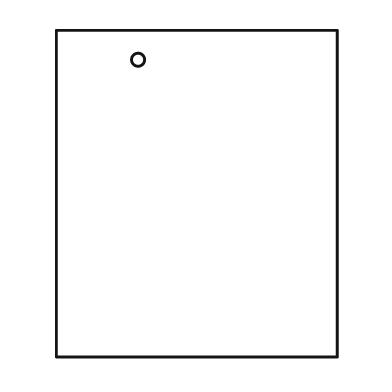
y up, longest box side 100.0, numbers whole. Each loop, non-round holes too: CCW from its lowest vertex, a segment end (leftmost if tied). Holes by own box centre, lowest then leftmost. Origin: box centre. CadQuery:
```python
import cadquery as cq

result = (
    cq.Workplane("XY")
    .moveTo(-43.0, -50.0)
    .lineTo(43.0, -50.0)
    .lineTo(43.0, 50.0)
    .lineTo(-43.0, 50.0)
    .close()
    .moveTo(-18.0, 41.0)
    .circle(2.0)
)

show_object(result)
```